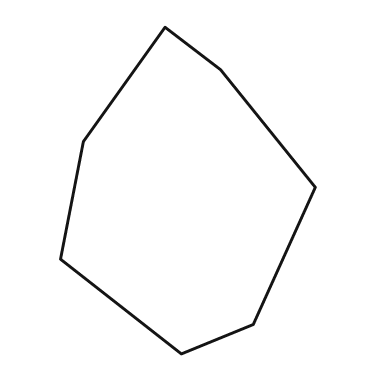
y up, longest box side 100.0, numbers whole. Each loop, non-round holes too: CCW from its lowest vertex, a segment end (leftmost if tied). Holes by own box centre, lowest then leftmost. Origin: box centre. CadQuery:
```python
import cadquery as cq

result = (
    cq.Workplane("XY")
    .moveTo(-2.0, -50.0)
    .lineTo(20.0, -41.0)
    .lineTo(39.0, 1.0)
    .lineTo(10.0, 37.0)
    .lineTo(-7.0, 50.0)
    .lineTo(-32.0, 15.0)
    .lineTo(-39.0, -21.0)
    .close()
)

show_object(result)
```